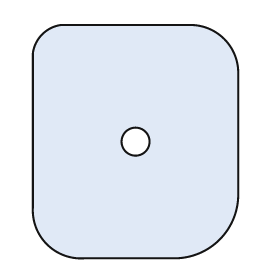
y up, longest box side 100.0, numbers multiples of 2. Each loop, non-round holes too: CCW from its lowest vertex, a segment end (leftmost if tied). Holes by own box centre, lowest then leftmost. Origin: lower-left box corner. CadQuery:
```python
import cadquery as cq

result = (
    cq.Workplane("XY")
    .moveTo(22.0, 0.0)
    .lineTo(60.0, 0.0)
    .threePointArc((80.0, 8.0), (88.0, 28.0))
    .lineTo(88.0, 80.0)
    .threePointArc((82.0, 94.0), (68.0, 100.0))
    .lineTo(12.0, 100.0)
    .threePointArc((4.0, 96.0), (0.0, 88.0))
    .lineTo(0.0, 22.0)
    .threePointArc((6.0, 6.0), (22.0, 0.0))
    .close()
    .moveTo(44.0, 50.0)
    .circle(6.0)
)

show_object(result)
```